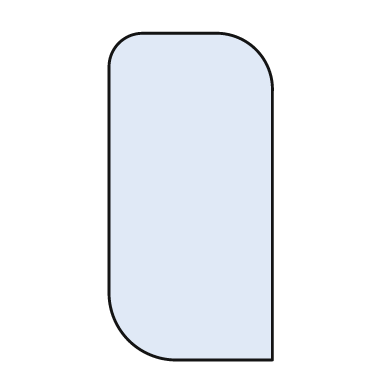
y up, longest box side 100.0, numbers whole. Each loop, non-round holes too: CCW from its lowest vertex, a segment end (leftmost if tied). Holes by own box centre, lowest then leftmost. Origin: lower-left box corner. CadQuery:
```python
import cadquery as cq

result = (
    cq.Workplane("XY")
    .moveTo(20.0, 0.0)
    .lineTo(50.0, 0.0)
    .lineTo(50.0, 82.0)
    .threePointArc((45.0, 95.0), (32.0, 100.0))
    .lineTo(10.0, 100.0)
    .threePointArc((3.0, 97.0), (0.0, 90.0))
    .lineTo(0.0, 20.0)
    .threePointArc((6.0, 6.0), (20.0, 0.0))
    .close()
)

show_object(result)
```